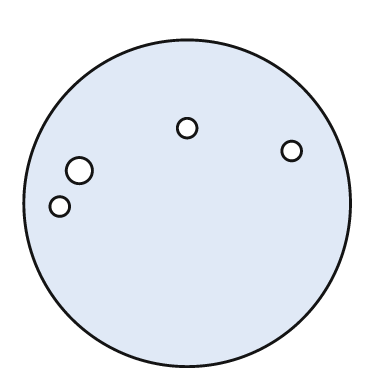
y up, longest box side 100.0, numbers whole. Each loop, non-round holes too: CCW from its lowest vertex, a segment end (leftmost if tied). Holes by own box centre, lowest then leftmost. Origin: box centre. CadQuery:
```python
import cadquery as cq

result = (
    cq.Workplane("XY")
    .moveTo(0.0, 0.0)
    .circle(50.0)
    .moveTo(-39.0, -1.0)
    .circle(3.0)
    .moveTo(-33.0, 10.0)
    .circle(4.0)
    .moveTo(32.0, 16.0)
    .circle(3.0)
    .moveTo(0.0, 23.0)
    .circle(3.0)
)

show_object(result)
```